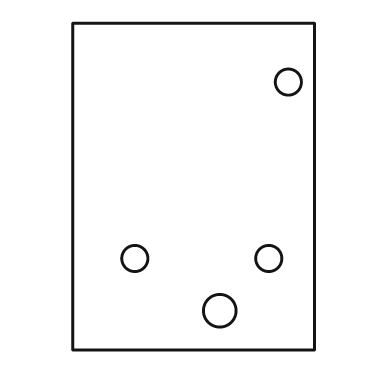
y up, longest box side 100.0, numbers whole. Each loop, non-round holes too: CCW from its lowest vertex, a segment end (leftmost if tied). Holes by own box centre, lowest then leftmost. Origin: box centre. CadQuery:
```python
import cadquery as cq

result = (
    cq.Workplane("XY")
    .moveTo(-37.0, -50.0)
    .lineTo(37.0, -50.0)
    .lineTo(37.0, 50.0)
    .lineTo(-37.0, 50.0)
    .close()
    .moveTo(8.0, -38.0)
    .circle(5.0)
    .moveTo(-18.0, -22.0)
    .circle(4.0)
    .moveTo(23.0, -22.0)
    .circle(4.0)
    .moveTo(29.0, 32.0)
    .circle(4.0)
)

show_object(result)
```